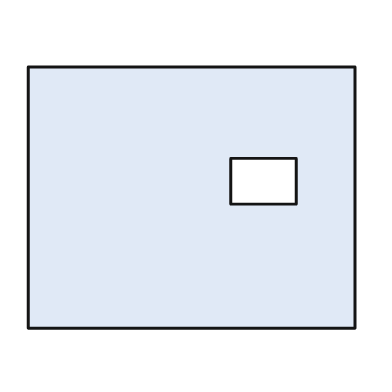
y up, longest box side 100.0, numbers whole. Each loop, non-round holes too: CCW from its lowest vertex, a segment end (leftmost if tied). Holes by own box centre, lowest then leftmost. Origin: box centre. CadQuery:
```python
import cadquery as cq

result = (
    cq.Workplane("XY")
    .moveTo(-50.0, -40.0)
    .lineTo(50.0, -40.0)
    .lineTo(50.0, 40.0)
    .lineTo(-50.0, 40.0)
    .close()
    .moveTo(12.0, -2.0)
    .lineTo(32.0, -2.0)
    .lineTo(32.0, 12.0)
    .lineTo(12.0, 12.0)
    .close()
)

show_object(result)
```